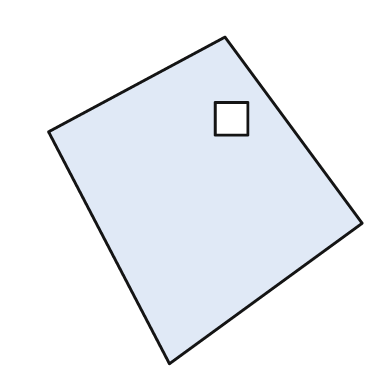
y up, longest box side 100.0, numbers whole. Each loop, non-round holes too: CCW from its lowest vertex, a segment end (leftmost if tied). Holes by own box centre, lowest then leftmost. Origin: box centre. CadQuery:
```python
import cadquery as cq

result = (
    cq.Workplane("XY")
    .moveTo(-11.0, -50.0)
    .lineTo(48.0, -7.0)
    .lineTo(6.0, 50.0)
    .lineTo(-48.0, 21.0)
    .close()
    .moveTo(3.0, 20.0)
    .lineTo(13.0, 20.0)
    .lineTo(13.0, 30.0)
    .lineTo(3.0, 30.0)
    .close()
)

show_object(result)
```